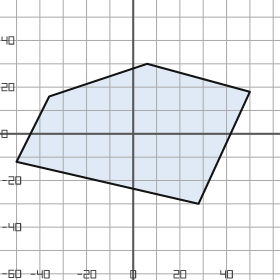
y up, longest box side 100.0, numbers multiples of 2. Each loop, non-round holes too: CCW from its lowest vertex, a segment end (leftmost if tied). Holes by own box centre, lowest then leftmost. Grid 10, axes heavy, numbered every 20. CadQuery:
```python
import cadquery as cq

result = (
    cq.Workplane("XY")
    .moveTo(28.0, -30.0)
    .lineTo(50.0, 18.0)
    .lineTo(6.0, 30.0)
    .lineTo(-36.0, 16.0)
    .lineTo(-50.0, -12.0)
    .close()
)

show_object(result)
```